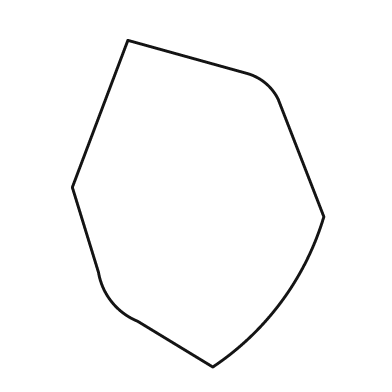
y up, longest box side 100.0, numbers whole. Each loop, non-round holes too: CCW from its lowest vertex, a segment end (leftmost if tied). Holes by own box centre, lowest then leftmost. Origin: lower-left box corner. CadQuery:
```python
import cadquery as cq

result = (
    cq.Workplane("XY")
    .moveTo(43.0, 0.0)
    .threePointArc((64.0, 20.0), (77.0, 46.0))
    .lineTo(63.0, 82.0)
    .threePointArc((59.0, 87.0), (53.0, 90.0))
    .lineTo(17.0, 100.0)
    .lineTo(0.0, 55.0)
    .lineTo(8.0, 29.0)
    .threePointArc((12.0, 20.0), (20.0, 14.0))
    .close()
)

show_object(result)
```